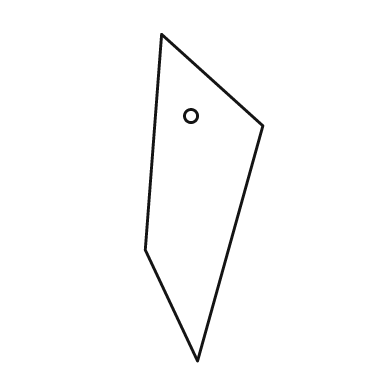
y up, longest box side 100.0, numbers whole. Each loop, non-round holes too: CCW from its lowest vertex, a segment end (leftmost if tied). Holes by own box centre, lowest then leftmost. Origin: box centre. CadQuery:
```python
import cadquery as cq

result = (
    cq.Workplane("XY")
    .moveTo(-2.0, -50.0)
    .lineTo(18.0, 22.0)
    .lineTo(-13.0, 50.0)
    .lineTo(-18.0, -16.0)
    .close()
    .moveTo(-4.0, 25.0)
    .circle(2.0)
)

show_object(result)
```